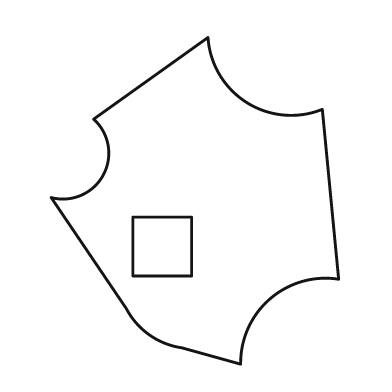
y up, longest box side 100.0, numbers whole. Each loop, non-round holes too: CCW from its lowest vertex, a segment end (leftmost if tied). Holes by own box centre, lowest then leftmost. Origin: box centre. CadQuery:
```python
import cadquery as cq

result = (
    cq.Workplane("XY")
    .moveTo(14.0, -50.0)
    .threePointArc((23.0, -30.0), (44.0, -24.0))
    .lineTo(39.0, 28.0)
    .threePointArc((16.0, 30.0), (4.0, 50.0))
    .lineTo(-31.0, 25.0)
    .threePointArc((-28.0, 8.0), (-44.0, 1.0))
    .lineTo(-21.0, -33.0)
    .threePointArc((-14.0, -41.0), (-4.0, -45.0))
    .close()
    .moveTo(-19.0, -23.0)
    .lineTo(-1.0, -23.0)
    .lineTo(-1.0, -5.0)
    .lineTo(-19.0, -5.0)
    .close()
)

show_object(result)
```